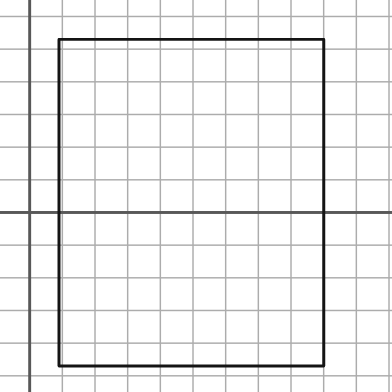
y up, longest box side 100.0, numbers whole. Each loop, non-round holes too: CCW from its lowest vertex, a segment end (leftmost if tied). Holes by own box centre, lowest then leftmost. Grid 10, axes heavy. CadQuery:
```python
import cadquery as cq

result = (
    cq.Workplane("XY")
    .moveTo(9.0, -47.0)
    .lineTo(90.0, -47.0)
    .lineTo(90.0, 53.0)
    .lineTo(9.0, 53.0)
    .close()
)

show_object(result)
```